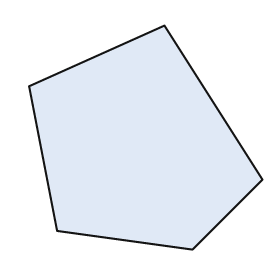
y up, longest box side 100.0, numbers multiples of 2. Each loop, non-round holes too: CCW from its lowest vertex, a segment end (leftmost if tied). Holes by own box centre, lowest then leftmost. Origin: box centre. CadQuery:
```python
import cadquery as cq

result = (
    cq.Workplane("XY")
    .moveTo(20.0, -48.0)
    .lineTo(50.0, -18.0)
    .lineTo(8.0, 48.0)
    .lineTo(-50.0, 22.0)
    .lineTo(-38.0, -40.0)
    .close()
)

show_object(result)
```